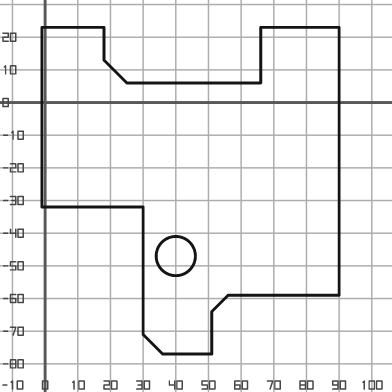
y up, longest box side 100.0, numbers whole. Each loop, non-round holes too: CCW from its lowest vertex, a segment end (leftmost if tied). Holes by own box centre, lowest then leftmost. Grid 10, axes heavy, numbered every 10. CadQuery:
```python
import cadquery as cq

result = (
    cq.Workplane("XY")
    .moveTo(36.0, -77.0)
    .lineTo(51.0, -77.0)
    .lineTo(51.0, -64.0)
    .lineTo(56.0, -59.0)
    .lineTo(90.0, -59.0)
    .lineTo(90.0, 23.0)
    .lineTo(66.0, 23.0)
    .lineTo(66.0, 6.0)
    .lineTo(25.0, 6.0)
    .lineTo(18.0, 13.0)
    .lineTo(18.0, 23.0)
    .lineTo(-1.0, 23.0)
    .lineTo(-1.0, -32.0)
    .lineTo(30.0, -32.0)
    .lineTo(30.0, -71.0)
    .close()
    .moveTo(40.0, -47.0)
    .circle(6.0)
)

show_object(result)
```